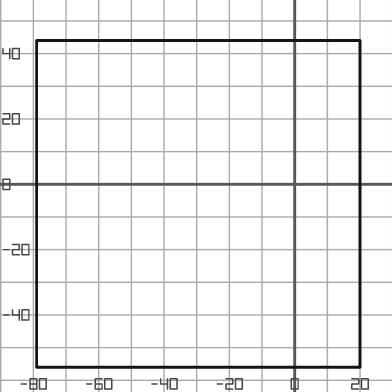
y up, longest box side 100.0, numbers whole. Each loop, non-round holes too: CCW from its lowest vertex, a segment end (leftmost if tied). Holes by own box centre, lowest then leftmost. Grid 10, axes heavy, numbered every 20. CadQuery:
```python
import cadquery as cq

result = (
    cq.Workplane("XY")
    .moveTo(-79.0, -56.0)
    .lineTo(20.0, -56.0)
    .lineTo(20.0, 44.0)
    .lineTo(-79.0, 44.0)
    .close()
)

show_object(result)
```